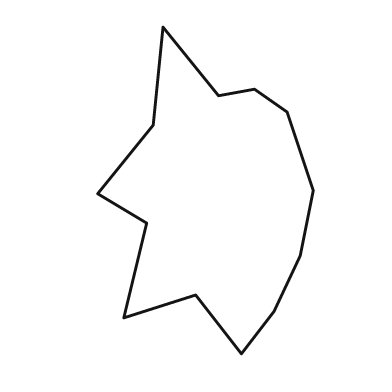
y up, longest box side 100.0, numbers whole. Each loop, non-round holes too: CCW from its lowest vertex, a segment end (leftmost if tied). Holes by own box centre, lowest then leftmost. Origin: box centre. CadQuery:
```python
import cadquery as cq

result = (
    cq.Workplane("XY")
    .moveTo(11.0, -50.0)
    .lineTo(21.0, -37.0)
    .lineTo(29.0, -20.0)
    .lineTo(33.0, 0.0)
    .lineTo(25.0, 24.0)
    .lineTo(15.0, 31.0)
    .lineTo(4.0, 29.0)
    .lineTo(-13.0, 50.0)
    .lineTo(-16.0, 20.0)
    .lineTo(-33.0, -1.0)
    .lineTo(-18.0, -10.0)
    .lineTo(-25.0, -39.0)
    .lineTo(-3.0, -32.0)
    .close()
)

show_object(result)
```